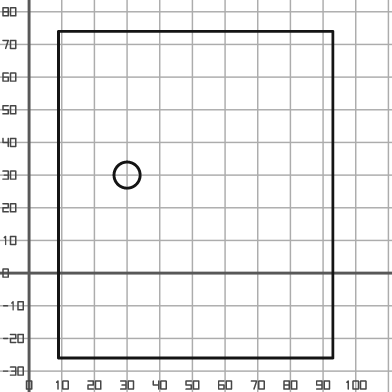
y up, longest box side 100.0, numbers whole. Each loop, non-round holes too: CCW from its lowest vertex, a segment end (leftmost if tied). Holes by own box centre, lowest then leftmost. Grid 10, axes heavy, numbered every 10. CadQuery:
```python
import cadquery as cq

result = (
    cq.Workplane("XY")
    .moveTo(9.0, -26.0)
    .lineTo(93.0, -26.0)
    .lineTo(93.0, 74.0)
    .lineTo(9.0, 74.0)
    .close()
    .moveTo(30.0, 30.0)
    .circle(4.0)
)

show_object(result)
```